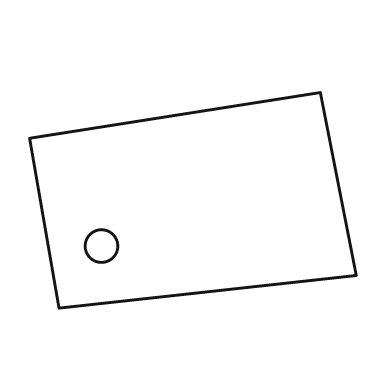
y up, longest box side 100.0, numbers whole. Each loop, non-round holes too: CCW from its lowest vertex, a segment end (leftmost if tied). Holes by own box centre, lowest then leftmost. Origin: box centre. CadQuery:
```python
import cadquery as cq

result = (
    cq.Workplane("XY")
    .moveTo(-41.0, -33.0)
    .lineTo(50.0, -23.0)
    .lineTo(39.0, 33.0)
    .lineTo(-50.0, 19.0)
    .close()
    .moveTo(-28.0, -14.0)
    .circle(5.0)
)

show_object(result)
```